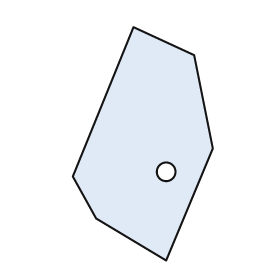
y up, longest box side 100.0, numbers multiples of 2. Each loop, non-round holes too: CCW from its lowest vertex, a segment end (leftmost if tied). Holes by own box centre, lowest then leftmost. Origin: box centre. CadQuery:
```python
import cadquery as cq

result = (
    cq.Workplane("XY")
    .moveTo(10.0, -50.0)
    .lineTo(30.0, -2.0)
    .lineTo(22.0, 38.0)
    .lineTo(-4.0, 50.0)
    .lineTo(-30.0, -14.0)
    .lineTo(-20.0, -32.0)
    .close()
    .moveTo(10.0, -12.0)
    .circle(4.0)
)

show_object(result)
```